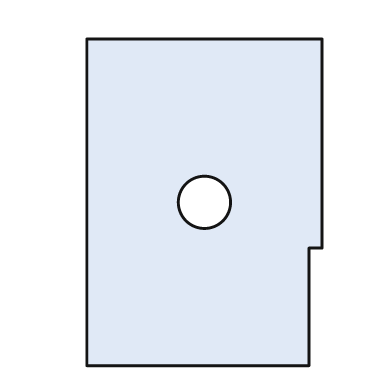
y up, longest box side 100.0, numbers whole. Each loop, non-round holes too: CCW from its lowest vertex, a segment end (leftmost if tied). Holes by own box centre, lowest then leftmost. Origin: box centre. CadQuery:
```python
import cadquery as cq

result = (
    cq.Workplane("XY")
    .moveTo(-36.0, -50.0)
    .lineTo(32.0, -50.0)
    .lineTo(32.0, -14.0)
    .lineTo(36.0, -14.0)
    .lineTo(36.0, 50.0)
    .lineTo(-36.0, 50.0)
    .close()
    .moveTo(0.0, 0.0)
    .circle(8.0)
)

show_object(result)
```